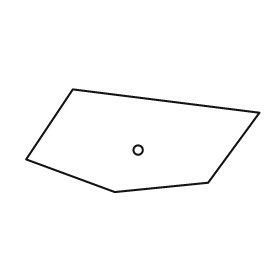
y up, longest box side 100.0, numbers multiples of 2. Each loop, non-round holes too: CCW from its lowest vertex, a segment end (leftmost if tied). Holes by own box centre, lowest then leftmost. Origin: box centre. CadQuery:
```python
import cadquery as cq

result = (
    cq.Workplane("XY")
    .moveTo(-12.0, -22.0)
    .lineTo(28.0, -18.0)
    .lineTo(50.0, 12.0)
    .lineTo(-30.0, 22.0)
    .lineTo(-50.0, -8.0)
    .close()
    .moveTo(-2.0, -4.0)
    .circle(2.0)
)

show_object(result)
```